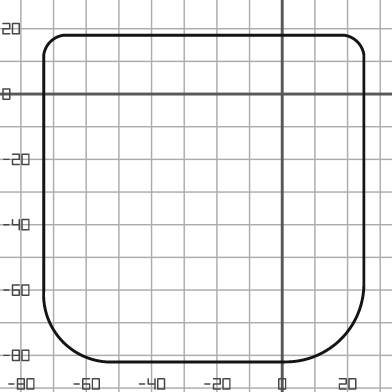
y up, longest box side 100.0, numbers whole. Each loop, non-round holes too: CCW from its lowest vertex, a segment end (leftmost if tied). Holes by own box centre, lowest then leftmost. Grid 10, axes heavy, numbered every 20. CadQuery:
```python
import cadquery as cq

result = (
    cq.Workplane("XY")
    .moveTo(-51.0, -82.0)
    .lineTo(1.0, -82.0)
    .threePointArc((18.0, -75.0), (25.0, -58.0))
    .lineTo(25.0, 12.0)
    .threePointArc((23.0, 16.0), (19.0, 18.0))
    .lineTo(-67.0, 18.0)
    .threePointArc((-71.0, 16.0), (-73.0, 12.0))
    .lineTo(-73.0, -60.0)
    .threePointArc((-67.0, -76.0), (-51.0, -82.0))
    .close()
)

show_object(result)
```